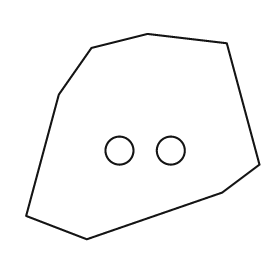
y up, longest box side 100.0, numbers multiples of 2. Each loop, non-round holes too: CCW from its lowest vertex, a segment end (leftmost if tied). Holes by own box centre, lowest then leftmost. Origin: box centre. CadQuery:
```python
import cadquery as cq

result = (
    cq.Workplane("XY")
    .moveTo(-24.0, -44.0)
    .lineTo(34.0, -24.0)
    .lineTo(50.0, -12.0)
    .lineTo(36.0, 40.0)
    .lineTo(2.0, 44.0)
    .lineTo(-22.0, 38.0)
    .lineTo(-36.0, 18.0)
    .lineTo(-50.0, -34.0)
    .close()
    .moveTo(-10.0, -6.0)
    .circle(6.0)
    .moveTo(12.0, -6.0)
    .circle(6.0)
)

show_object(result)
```